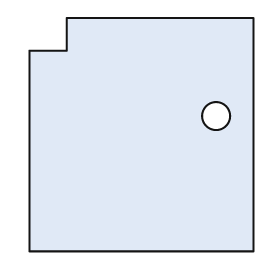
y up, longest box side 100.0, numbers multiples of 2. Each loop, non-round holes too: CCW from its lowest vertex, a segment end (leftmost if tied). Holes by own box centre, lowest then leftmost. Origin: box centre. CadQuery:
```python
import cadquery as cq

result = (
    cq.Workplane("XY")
    .moveTo(-48.0, -50.0)
    .lineTo(48.0, -50.0)
    .lineTo(48.0, 50.0)
    .lineTo(-32.0, 50.0)
    .lineTo(-32.0, 36.0)
    .lineTo(-48.0, 36.0)
    .close()
    .moveTo(32.0, 8.0)
    .circle(6.0)
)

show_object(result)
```